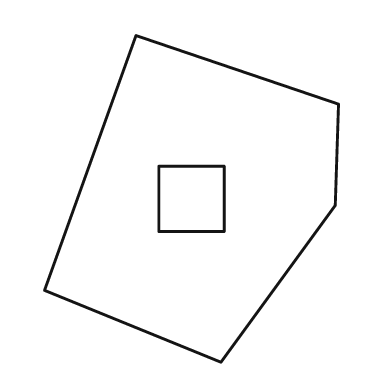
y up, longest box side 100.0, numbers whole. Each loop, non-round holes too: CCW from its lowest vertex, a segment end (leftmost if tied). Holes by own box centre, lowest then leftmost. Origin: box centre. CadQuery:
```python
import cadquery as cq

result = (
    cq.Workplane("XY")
    .moveTo(9.0, -50.0)
    .lineTo(44.0, -2.0)
    .lineTo(45.0, 29.0)
    .lineTo(-17.0, 50.0)
    .lineTo(-45.0, -28.0)
    .close()
    .moveTo(-10.0, -10.0)
    .lineTo(10.0, -10.0)
    .lineTo(10.0, 10.0)
    .lineTo(-10.0, 10.0)
    .close()
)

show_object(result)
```